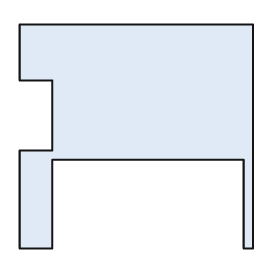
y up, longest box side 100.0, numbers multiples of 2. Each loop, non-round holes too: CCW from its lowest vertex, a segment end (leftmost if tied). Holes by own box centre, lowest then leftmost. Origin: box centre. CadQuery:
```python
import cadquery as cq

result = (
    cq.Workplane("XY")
    .moveTo(-50.0, -48.0)
    .lineTo(-36.0, -48.0)
    .lineTo(-36.0, -10.0)
    .lineTo(46.0, -10.0)
    .lineTo(46.0, -48.0)
    .lineTo(50.0, -48.0)
    .lineTo(50.0, 48.0)
    .lineTo(-50.0, 48.0)
    .lineTo(-50.0, 24.0)
    .lineTo(-36.0, 24.0)
    .lineTo(-36.0, -6.0)
    .lineTo(-50.0, -6.0)
    .close()
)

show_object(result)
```